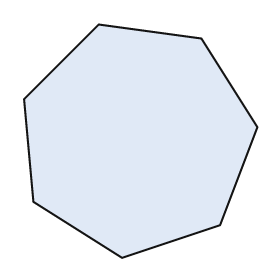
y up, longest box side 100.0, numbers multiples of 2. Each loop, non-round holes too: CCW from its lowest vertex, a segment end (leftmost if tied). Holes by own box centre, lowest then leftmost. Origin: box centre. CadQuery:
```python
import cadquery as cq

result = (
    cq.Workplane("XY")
    .moveTo(-8.0, -50.0)
    .lineTo(34.0, -36.0)
    .lineTo(50.0, 6.0)
    .lineTo(26.0, 44.0)
    .lineTo(-18.0, 50.0)
    .lineTo(-50.0, 18.0)
    .lineTo(-46.0, -26.0)
    .close()
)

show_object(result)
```